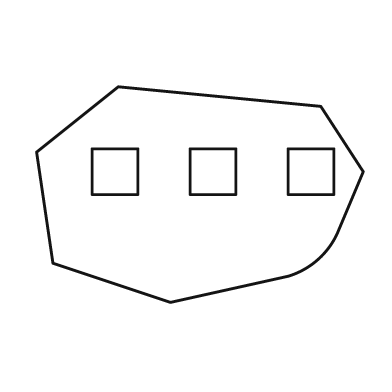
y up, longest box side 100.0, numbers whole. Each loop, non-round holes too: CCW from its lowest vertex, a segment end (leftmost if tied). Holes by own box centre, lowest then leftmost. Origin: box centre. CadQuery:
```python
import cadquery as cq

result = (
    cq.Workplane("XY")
    .moveTo(-9.0, -33.0)
    .lineTo(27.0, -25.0)
    .threePointArc((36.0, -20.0), (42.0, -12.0))
    .lineTo(50.0, 7.0)
    .lineTo(37.0, 27.0)
    .lineTo(-25.0, 33.0)
    .lineTo(-50.0, 13.0)
    .lineTo(-45.0, -21.0)
    .close()
    .moveTo(-33.0, 0.0)
    .lineTo(-19.0, 0.0)
    .lineTo(-19.0, 14.0)
    .lineTo(-33.0, 14.0)
    .close()
    .moveTo(-3.0, 0.0)
    .lineTo(11.0, 0.0)
    .lineTo(11.0, 14.0)
    .lineTo(-3.0, 14.0)
    .close()
    .moveTo(27.0, 0.0)
    .lineTo(41.0, 0.0)
    .lineTo(41.0, 14.0)
    .lineTo(27.0, 14.0)
    .close()
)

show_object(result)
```